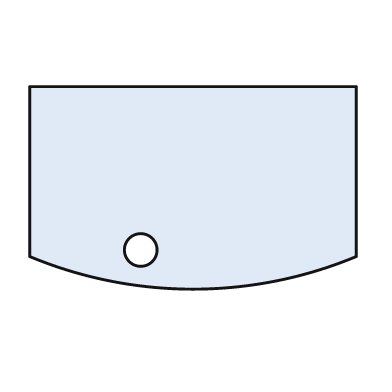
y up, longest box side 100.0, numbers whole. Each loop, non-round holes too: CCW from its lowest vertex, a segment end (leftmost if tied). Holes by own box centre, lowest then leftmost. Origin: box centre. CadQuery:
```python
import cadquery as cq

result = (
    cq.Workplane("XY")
    .moveTo(-50.0, -21.0)
    .threePointArc((0.0, -31.0), (50.0, -21.0))
    .lineTo(50.0, 31.0)
    .lineTo(-50.0, 31.0)
    .close()
    .moveTo(-16.0, -19.0)
    .circle(5.0)
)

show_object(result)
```